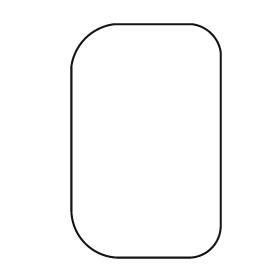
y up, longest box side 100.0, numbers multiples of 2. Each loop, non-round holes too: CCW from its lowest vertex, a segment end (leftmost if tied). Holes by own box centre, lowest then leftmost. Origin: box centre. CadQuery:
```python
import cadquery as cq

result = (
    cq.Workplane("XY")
    .moveTo(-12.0, -50.0)
    .lineTo(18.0, -50.0)
    .threePointArc((28.0, -46.0), (32.0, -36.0))
    .lineTo(32.0, 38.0)
    .threePointArc((28.0, 46.0), (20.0, 50.0))
    .lineTo(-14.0, 50.0)
    .threePointArc((-26.0, 44.0), (-32.0, 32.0))
    .lineTo(-32.0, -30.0)
    .threePointArc((-26.0, -44.0), (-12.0, -50.0))
    .close()
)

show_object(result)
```